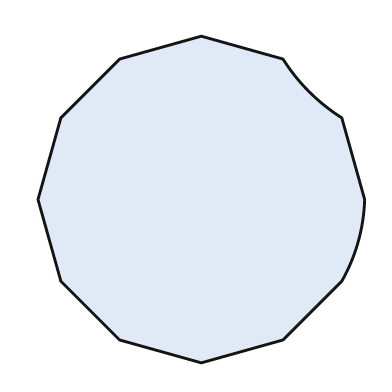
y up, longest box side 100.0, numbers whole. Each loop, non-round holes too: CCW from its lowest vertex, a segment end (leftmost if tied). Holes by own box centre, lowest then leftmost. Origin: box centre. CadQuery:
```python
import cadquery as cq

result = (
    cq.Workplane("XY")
    .moveTo(0.0, -50.0)
    .lineTo(25.0, -43.0)
    .lineTo(43.0, -25.0)
    .threePointArc((48.0, -13.0), (50.0, 0.0))
    .lineTo(43.0, 25.0)
    .threePointArc((33.0, 33.0), (25.0, 43.0))
    .lineTo(0.0, 50.0)
    .lineTo(-25.0, 43.0)
    .lineTo(-43.0, 25.0)
    .lineTo(-50.0, 0.0)
    .lineTo(-43.0, -25.0)
    .lineTo(-25.0, -43.0)
    .close()
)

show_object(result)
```